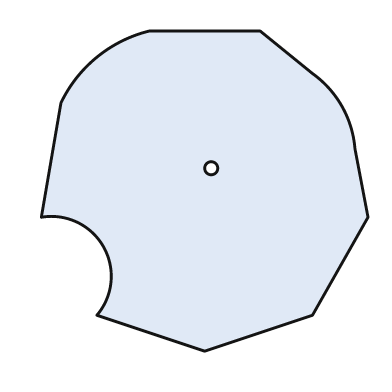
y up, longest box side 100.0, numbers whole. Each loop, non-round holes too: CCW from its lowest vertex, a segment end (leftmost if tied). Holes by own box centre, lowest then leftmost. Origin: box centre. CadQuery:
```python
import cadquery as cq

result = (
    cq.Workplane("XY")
    .moveTo(0.0, -49.0)
    .lineTo(33.0, -38.0)
    .lineTo(50.0, -8.0)
    .lineTo(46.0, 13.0)
    .threePointArc((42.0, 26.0), (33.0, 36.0))
    .lineTo(17.0, 49.0)
    .lineTo(-17.0, 49.0)
    .threePointArc((-33.0, 41.0), (-44.0, 27.0))
    .lineTo(-50.0, -8.0)
    .threePointArc((-31.0, -17.0), (-33.0, -38.0))
    .close()
    .moveTo(2.0, 7.0)
    .circle(2.0)
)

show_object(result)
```